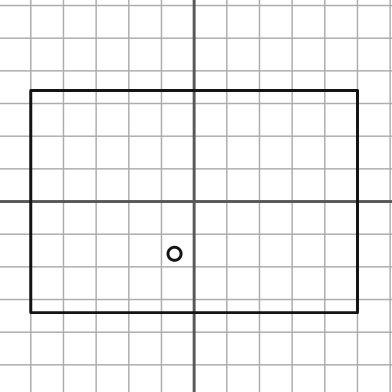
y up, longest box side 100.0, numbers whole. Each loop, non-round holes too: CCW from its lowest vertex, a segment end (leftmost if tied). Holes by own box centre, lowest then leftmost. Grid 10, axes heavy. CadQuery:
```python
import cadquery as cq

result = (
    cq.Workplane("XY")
    .moveTo(-50.0, -34.0)
    .lineTo(50.0, -34.0)
    .lineTo(50.0, 34.0)
    .lineTo(-50.0, 34.0)
    .close()
    .moveTo(-6.0, -16.0)
    .circle(2.0)
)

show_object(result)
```